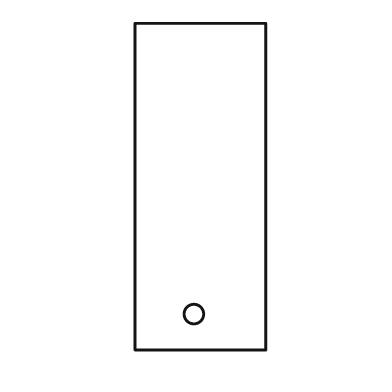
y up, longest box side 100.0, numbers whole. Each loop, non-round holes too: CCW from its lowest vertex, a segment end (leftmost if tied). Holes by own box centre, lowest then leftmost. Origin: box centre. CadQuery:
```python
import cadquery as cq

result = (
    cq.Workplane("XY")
    .moveTo(-20.0, -50.0)
    .lineTo(20.0, -50.0)
    .lineTo(20.0, 50.0)
    .lineTo(-20.0, 50.0)
    .close()
    .moveTo(-2.0, -39.0)
    .circle(3.0)
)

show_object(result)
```